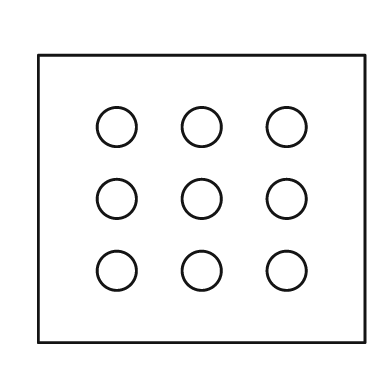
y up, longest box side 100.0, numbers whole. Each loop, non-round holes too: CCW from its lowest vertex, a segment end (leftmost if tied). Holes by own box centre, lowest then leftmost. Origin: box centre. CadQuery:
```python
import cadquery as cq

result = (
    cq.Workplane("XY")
    .moveTo(-50.0, -44.0)
    .lineTo(50.0, -44.0)
    .lineTo(50.0, 44.0)
    .lineTo(-50.0, 44.0)
    .close()
    .moveTo(-26.0, -22.0)
    .circle(6.0)
    .moveTo(0.0, -22.0)
    .circle(6.0)
    .moveTo(26.0, -22.0)
    .circle(6.0)
    .moveTo(-26.0, 0.0)
    .circle(6.0)
    .moveTo(0.0, 0.0)
    .circle(6.0)
    .moveTo(26.0, 0.0)
    .circle(6.0)
    .moveTo(-26.0, 22.0)
    .circle(6.0)
    .moveTo(0.0, 22.0)
    .circle(6.0)
    .moveTo(26.0, 22.0)
    .circle(6.0)
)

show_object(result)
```